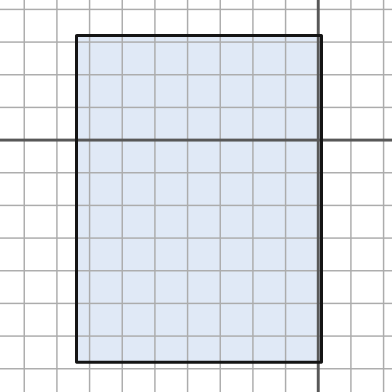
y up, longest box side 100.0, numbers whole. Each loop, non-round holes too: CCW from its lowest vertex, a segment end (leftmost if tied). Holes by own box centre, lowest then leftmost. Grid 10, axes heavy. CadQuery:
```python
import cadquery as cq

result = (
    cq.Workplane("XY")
    .moveTo(-74.0, -68.0)
    .lineTo(1.0, -68.0)
    .lineTo(1.0, 32.0)
    .lineTo(-74.0, 32.0)
    .close()
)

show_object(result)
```